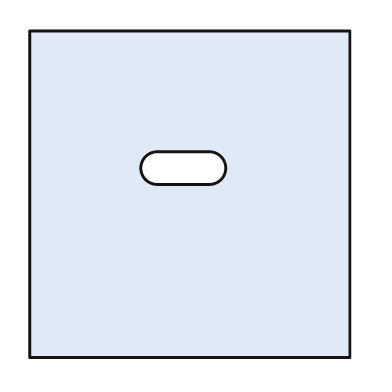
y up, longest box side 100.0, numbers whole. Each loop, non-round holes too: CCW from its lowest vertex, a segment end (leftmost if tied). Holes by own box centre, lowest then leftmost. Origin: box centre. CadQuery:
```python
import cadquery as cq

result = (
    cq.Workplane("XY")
    .moveTo(-49.0, -50.0)
    .lineTo(49.0, -50.0)
    .lineTo(49.0, 50.0)
    .lineTo(-49.0, 50.0)
    .close()
    .moveTo(-10.0, 3.0)
    .lineTo(6.0, 3.0)
    .threePointArc((11.0, 8.0), (6.0, 13.0))
    .lineTo(-10.0, 13.0)
    .threePointArc((-15.0, 8.0), (-10.0, 3.0))
    .close()
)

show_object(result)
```